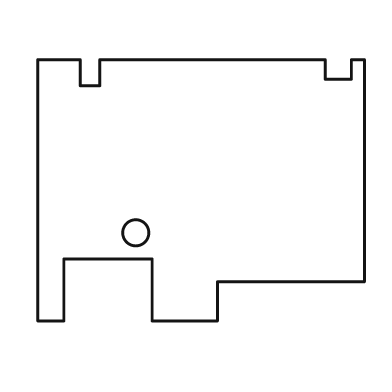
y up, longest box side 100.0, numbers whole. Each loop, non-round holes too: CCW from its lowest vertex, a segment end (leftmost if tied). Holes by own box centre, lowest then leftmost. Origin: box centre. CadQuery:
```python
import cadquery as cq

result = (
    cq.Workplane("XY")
    .moveTo(-50.0, -40.0)
    .lineTo(-42.0, -40.0)
    .lineTo(-42.0, -21.0)
    .lineTo(-15.0, -21.0)
    .lineTo(-15.0, -40.0)
    .lineTo(5.0, -40.0)
    .lineTo(5.0, -28.0)
    .lineTo(50.0, -28.0)
    .lineTo(50.0, 40.0)
    .lineTo(46.0, 40.0)
    .lineTo(46.0, 34.0)
    .lineTo(38.0, 34.0)
    .lineTo(38.0, 40.0)
    .lineTo(-31.0, 40.0)
    .lineTo(-31.0, 32.0)
    .lineTo(-37.0, 32.0)
    .lineTo(-37.0, 40.0)
    .lineTo(-50.0, 40.0)
    .close()
    .moveTo(-20.0, -13.0)
    .circle(4.0)
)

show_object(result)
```